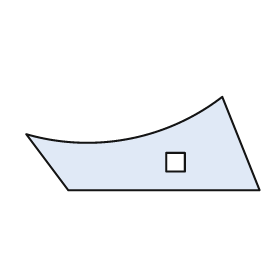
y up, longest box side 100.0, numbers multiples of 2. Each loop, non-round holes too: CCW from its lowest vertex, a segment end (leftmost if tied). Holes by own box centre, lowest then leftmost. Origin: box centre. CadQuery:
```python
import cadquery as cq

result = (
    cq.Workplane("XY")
    .moveTo(-32.0, -20.0)
    .lineTo(50.0, -20.0)
    .lineTo(34.0, 20.0)
    .threePointArc((-6.0, 2.0), (-50.0, 4.0))
    .close()
    .moveTo(10.0, -12.0)
    .lineTo(18.0, -12.0)
    .lineTo(18.0, -4.0)
    .lineTo(10.0, -4.0)
    .close()
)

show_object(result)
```